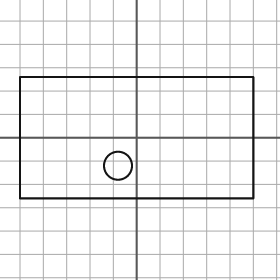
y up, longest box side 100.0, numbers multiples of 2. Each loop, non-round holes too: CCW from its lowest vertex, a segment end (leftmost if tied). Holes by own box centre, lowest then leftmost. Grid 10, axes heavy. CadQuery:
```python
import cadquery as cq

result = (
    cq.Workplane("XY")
    .moveTo(-50.0, -26.0)
    .lineTo(50.0, -26.0)
    .lineTo(50.0, 26.0)
    .lineTo(-50.0, 26.0)
    .close()
    .moveTo(-8.0, -12.0)
    .circle(6.0)
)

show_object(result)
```